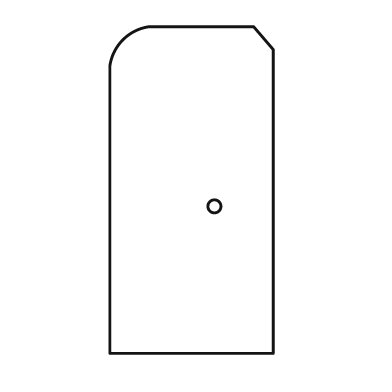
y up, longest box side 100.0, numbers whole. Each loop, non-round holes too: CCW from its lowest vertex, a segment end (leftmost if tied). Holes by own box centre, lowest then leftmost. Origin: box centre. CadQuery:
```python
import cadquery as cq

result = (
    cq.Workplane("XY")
    .moveTo(-25.0, -50.0)
    .lineTo(25.0, -50.0)
    .lineTo(25.0, 43.0)
    .lineTo(19.0, 50.0)
    .lineTo(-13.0, 50.0)
    .threePointArc((-21.0, 46.0), (-25.0, 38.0))
    .close()
    .moveTo(7.0, -5.0)
    .circle(2.0)
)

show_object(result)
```